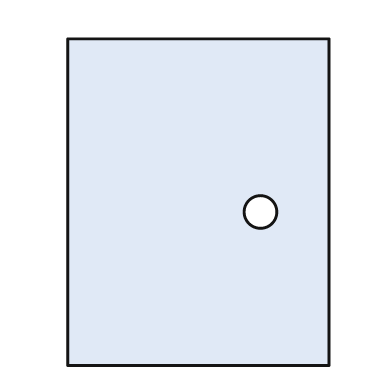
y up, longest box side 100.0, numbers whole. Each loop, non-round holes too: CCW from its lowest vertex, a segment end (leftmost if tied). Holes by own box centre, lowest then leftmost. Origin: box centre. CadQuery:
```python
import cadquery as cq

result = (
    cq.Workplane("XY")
    .moveTo(-40.0, -50.0)
    .lineTo(40.0, -50.0)
    .lineTo(40.0, 50.0)
    .lineTo(-40.0, 50.0)
    .close()
    .moveTo(19.0, -3.0)
    .circle(5.0)
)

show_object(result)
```